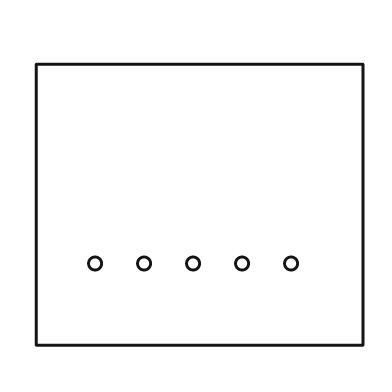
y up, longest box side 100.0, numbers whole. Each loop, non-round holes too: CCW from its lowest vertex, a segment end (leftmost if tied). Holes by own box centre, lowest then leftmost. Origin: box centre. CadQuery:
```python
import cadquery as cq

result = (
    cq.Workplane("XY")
    .moveTo(-50.0, -43.0)
    .lineTo(50.0, -43.0)
    .lineTo(50.0, 43.0)
    .lineTo(-50.0, 43.0)
    .close()
    .moveTo(-32.0, -18.0)
    .circle(2.0)
    .moveTo(-17.0, -18.0)
    .circle(2.0)
    .moveTo(-2.0, -18.0)
    .circle(2.0)
    .moveTo(13.0, -18.0)
    .circle(2.0)
    .moveTo(28.0, -18.0)
    .circle(2.0)
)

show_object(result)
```